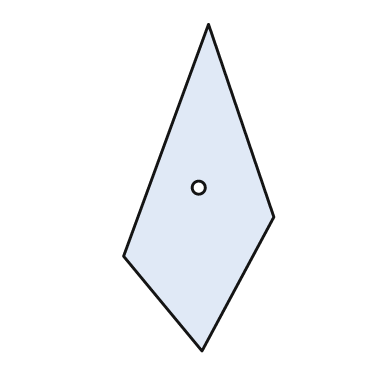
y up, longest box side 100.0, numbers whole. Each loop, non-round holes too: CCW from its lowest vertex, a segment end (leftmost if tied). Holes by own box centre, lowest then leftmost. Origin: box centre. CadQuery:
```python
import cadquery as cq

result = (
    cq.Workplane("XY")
    .moveTo(1.0, -50.0)
    .lineTo(23.0, -9.0)
    .lineTo(3.0, 50.0)
    .lineTo(-23.0, -21.0)
    .close()
    .moveTo(0.0, 0.0)
    .circle(2.0)
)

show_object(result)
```